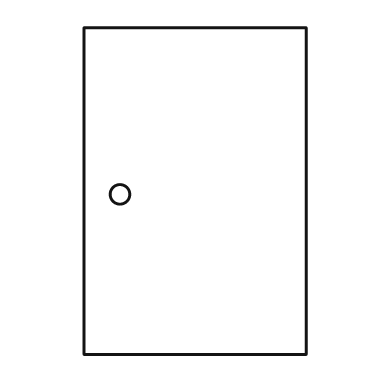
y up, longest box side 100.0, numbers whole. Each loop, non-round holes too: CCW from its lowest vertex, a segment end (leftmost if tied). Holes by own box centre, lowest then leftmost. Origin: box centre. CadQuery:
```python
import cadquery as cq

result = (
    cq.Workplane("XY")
    .moveTo(-34.0, -50.0)
    .lineTo(34.0, -50.0)
    .lineTo(34.0, 50.0)
    .lineTo(-34.0, 50.0)
    .close()
    .moveTo(-23.0, -1.0)
    .circle(3.0)
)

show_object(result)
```